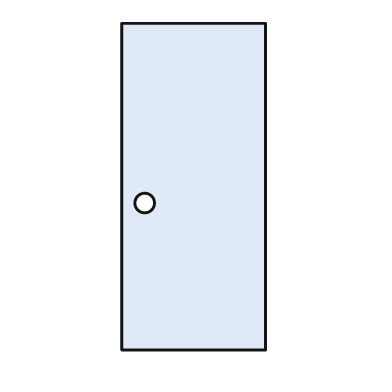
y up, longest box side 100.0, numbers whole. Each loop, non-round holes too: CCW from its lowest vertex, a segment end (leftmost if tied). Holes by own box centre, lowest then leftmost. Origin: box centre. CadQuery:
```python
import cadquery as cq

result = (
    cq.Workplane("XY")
    .moveTo(-22.0, -50.0)
    .lineTo(22.0, -50.0)
    .lineTo(22.0, 50.0)
    .lineTo(-22.0, 50.0)
    .close()
    .moveTo(-15.0, -5.0)
    .circle(3.0)
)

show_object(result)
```